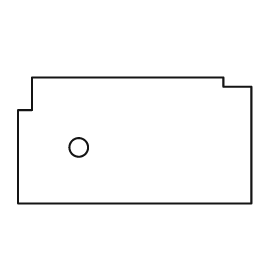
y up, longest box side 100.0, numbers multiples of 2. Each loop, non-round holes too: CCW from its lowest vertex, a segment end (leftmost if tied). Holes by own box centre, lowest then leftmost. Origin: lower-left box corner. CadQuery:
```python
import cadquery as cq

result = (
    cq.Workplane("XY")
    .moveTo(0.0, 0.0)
    .lineTo(100.0, 0.0)
    .lineTo(100.0, 50.0)
    .lineTo(88.0, 50.0)
    .lineTo(88.0, 54.0)
    .lineTo(6.0, 54.0)
    .lineTo(6.0, 40.0)
    .lineTo(0.0, 40.0)
    .close()
    .moveTo(26.0, 24.0)
    .circle(4.0)
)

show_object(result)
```